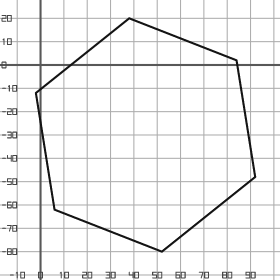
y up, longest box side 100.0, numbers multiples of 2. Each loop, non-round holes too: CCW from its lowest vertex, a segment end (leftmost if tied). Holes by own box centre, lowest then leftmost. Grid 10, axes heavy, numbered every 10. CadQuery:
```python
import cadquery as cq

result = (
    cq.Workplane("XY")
    .moveTo(52.0, -80.0)
    .lineTo(92.0, -48.0)
    .lineTo(84.0, 2.0)
    .lineTo(38.0, 20.0)
    .lineTo(-2.0, -12.0)
    .lineTo(6.0, -62.0)
    .close()
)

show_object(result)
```